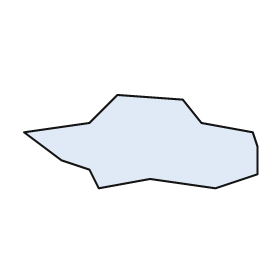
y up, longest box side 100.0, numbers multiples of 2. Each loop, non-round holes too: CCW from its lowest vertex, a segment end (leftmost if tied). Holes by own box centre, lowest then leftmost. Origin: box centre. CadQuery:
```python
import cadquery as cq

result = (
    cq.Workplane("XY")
    .moveTo(-18.0, -20.0)
    .lineTo(4.0, -16.0)
    .lineTo(32.0, -20.0)
    .lineTo(50.0, -14.0)
    .lineTo(50.0, -2.0)
    .lineTo(48.0, 4.0)
    .lineTo(26.0, 8.0)
    .lineTo(18.0, 18.0)
    .lineTo(-10.0, 20.0)
    .lineTo(-22.0, 8.0)
    .lineTo(-50.0, 4.0)
    .lineTo(-34.0, -8.0)
    .lineTo(-22.0, -12.0)
    .close()
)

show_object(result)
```